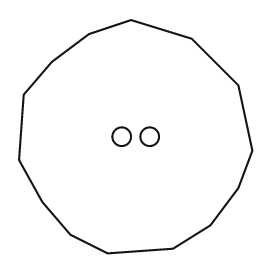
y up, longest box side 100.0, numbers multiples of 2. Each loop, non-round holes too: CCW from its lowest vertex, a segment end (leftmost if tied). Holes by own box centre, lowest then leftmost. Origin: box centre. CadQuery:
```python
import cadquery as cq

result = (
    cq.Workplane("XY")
    .moveTo(-12.0, -50.0)
    .lineTo(16.0, -48.0)
    .lineTo(32.0, -38.0)
    .lineTo(44.0, -22.0)
    .lineTo(50.0, -6.0)
    .lineTo(44.0, 22.0)
    .lineTo(24.0, 42.0)
    .lineTo(-2.0, 50.0)
    .lineTo(-20.0, 44.0)
    .lineTo(-36.0, 32.0)
    .lineTo(-48.0, 18.0)
    .lineTo(-50.0, -10.0)
    .lineTo(-40.0, -28.0)
    .lineTo(-28.0, -42.0)
    .close()
    .moveTo(-6.0, 0.0)
    .circle(4.0)
    .moveTo(6.0, 0.0)
    .circle(4.0)
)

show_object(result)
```